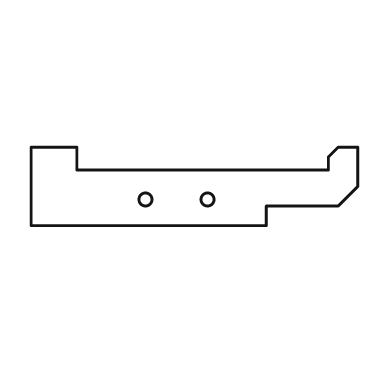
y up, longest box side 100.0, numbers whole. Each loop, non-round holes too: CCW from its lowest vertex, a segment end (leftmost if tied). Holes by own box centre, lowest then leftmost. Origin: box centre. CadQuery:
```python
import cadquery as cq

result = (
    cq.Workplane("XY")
    .moveTo(-50.0, -12.0)
    .lineTo(22.0, -12.0)
    .lineTo(22.0, -6.0)
    .lineTo(44.0, -6.0)
    .lineTo(50.0, 0.0)
    .lineTo(50.0, 12.0)
    .lineTo(44.0, 12.0)
    .lineTo(41.0, 9.0)
    .lineTo(41.0, 5.0)
    .lineTo(-36.0, 5.0)
    .lineTo(-36.0, 12.0)
    .lineTo(-50.0, 12.0)
    .close()
    .moveTo(-15.0, -4.0)
    .circle(2.0)
    .moveTo(4.0, -4.0)
    .circle(2.0)
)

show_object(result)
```